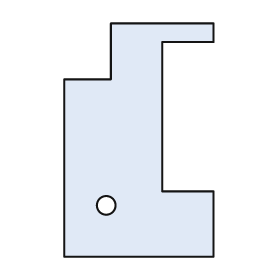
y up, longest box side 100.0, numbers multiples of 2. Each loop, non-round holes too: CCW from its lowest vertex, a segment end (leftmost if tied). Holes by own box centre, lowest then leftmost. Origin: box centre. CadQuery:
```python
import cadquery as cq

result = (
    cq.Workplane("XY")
    .moveTo(-32.0, -50.0)
    .lineTo(32.0, -50.0)
    .lineTo(32.0, -22.0)
    .lineTo(10.0, -22.0)
    .lineTo(10.0, 42.0)
    .lineTo(32.0, 42.0)
    .lineTo(32.0, 50.0)
    .lineTo(-12.0, 50.0)
    .lineTo(-12.0, 26.0)
    .lineTo(-32.0, 26.0)
    .close()
    .moveTo(-14.0, -28.0)
    .circle(4.0)
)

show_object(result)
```